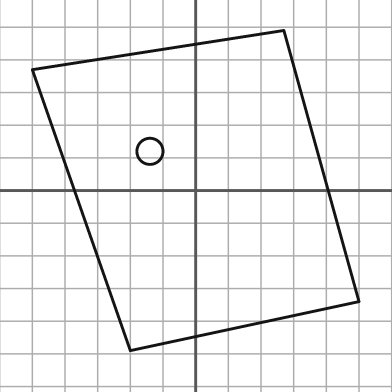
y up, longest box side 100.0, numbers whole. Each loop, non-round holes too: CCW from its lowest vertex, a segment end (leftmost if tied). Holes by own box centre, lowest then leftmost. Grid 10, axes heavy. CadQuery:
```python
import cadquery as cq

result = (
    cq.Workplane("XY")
    .moveTo(-20.0, -49.0)
    .lineTo(50.0, -34.0)
    .lineTo(27.0, 49.0)
    .lineTo(-50.0, 37.0)
    .close()
    .moveTo(-14.0, 12.0)
    .circle(4.0)
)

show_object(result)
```